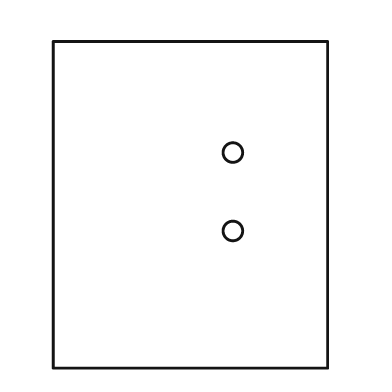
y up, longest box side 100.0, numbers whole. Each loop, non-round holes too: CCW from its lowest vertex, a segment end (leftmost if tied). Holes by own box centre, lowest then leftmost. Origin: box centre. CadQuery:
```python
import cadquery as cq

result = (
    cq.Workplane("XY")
    .moveTo(-42.0, -50.0)
    .lineTo(42.0, -50.0)
    .lineTo(42.0, 50.0)
    .lineTo(-42.0, 50.0)
    .close()
    .moveTo(13.0, -8.0)
    .circle(3.0)
    .moveTo(13.0, 16.0)
    .circle(3.0)
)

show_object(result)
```